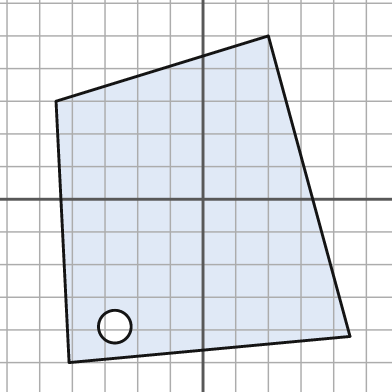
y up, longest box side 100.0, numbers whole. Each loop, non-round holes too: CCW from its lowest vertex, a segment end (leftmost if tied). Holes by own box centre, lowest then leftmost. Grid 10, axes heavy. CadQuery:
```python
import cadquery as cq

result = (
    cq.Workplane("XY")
    .moveTo(-41.0, -50.0)
    .lineTo(45.0, -42.0)
    .lineTo(20.0, 50.0)
    .lineTo(-45.0, 30.0)
    .close()
    .moveTo(-27.0, -39.0)
    .circle(5.0)
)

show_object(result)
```